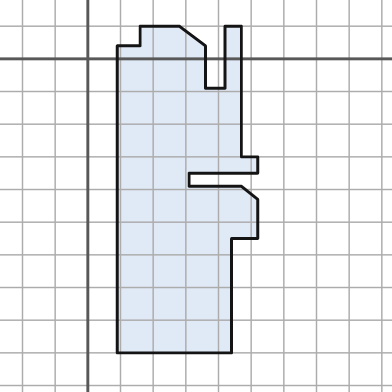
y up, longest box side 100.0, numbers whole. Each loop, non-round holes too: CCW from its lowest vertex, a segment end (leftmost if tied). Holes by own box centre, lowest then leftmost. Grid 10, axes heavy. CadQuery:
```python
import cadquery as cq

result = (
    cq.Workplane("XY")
    .moveTo(9.0, -90.0)
    .lineTo(44.0, -90.0)
    .lineTo(44.0, -55.0)
    .lineTo(52.0, -55.0)
    .lineTo(52.0, -43.0)
    .lineTo(47.0, -39.0)
    .lineTo(31.0, -39.0)
    .lineTo(31.0, -35.0)
    .lineTo(52.0, -35.0)
    .lineTo(52.0, -30.0)
    .lineTo(47.0, -30.0)
    .lineTo(47.0, 10.0)
    .lineTo(42.0, 10.0)
    .lineTo(42.0, -9.0)
    .lineTo(36.0, -9.0)
    .lineTo(36.0, 4.0)
    .lineTo(28.0, 10.0)
    .lineTo(16.0, 10.0)
    .lineTo(16.0, 4.0)
    .lineTo(9.0, 4.0)
    .close()
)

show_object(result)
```